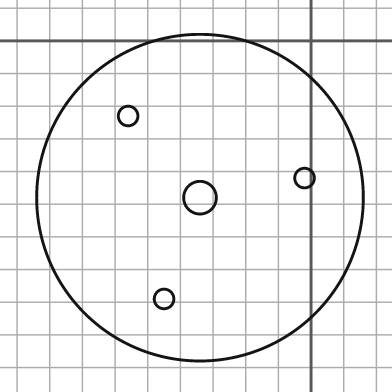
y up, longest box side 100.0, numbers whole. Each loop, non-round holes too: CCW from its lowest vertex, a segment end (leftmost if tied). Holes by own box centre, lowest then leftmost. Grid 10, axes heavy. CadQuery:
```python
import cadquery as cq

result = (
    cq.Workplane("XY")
    .moveTo(-34.0, -48.0)
    .circle(50.0)
    .moveTo(-45.0, -79.0)
    .circle(3.0)
    .moveTo(-34.0, -48.0)
    .circle(5.0)
    .moveTo(-2.0, -42.0)
    .circle(3.0)
    .moveTo(-56.0, -23.0)
    .circle(3.0)
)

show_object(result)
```